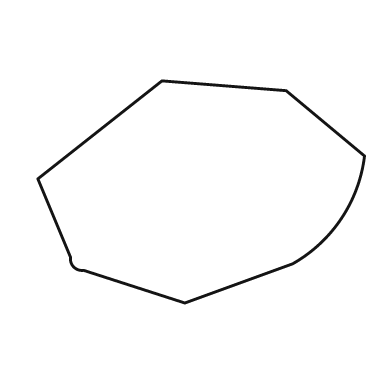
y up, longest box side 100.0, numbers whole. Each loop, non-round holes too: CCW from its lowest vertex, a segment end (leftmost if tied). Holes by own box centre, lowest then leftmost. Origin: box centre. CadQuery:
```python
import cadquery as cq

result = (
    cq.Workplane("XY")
    .moveTo(-5.0, -34.0)
    .lineTo(28.0, -22.0)
    .threePointArc((43.0, -8.0), (50.0, 11.0))
    .lineTo(26.0, 31.0)
    .lineTo(-12.0, 34.0)
    .lineTo(-50.0, 4.0)
    .lineTo(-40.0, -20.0)
    .threePointArc((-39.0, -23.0), (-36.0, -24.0))
    .close()
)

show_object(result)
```